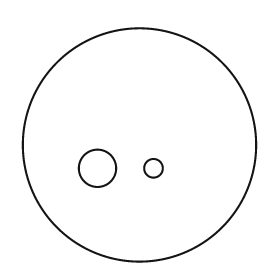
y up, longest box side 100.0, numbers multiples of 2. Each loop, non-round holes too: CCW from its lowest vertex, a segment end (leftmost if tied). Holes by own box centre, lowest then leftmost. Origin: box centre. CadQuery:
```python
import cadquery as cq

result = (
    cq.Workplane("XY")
    .moveTo(0.0, 0.0)
    .circle(50.0)
    .moveTo(-18.0, -10.0)
    .circle(8.0)
    .moveTo(6.0, -10.0)
    .circle(4.0)
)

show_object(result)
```